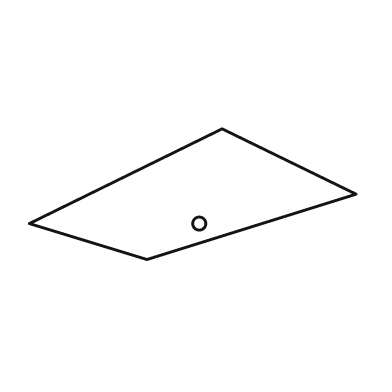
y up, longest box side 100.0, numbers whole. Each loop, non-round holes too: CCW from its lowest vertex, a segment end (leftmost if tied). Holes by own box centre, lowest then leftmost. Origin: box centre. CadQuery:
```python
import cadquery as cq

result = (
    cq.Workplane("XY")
    .moveTo(-14.0, -20.0)
    .lineTo(50.0, 0.0)
    .lineTo(9.0, 20.0)
    .lineTo(-50.0, -9.0)
    .close()
    .moveTo(2.0, -9.0)
    .circle(2.0)
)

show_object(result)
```